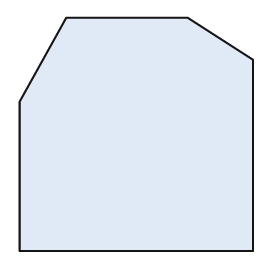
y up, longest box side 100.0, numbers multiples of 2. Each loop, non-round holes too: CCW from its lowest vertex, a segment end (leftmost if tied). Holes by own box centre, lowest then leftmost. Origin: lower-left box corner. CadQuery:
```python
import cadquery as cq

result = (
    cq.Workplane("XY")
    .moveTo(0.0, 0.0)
    .lineTo(100.0, 0.0)
    .lineTo(100.0, 82.0)
    .lineTo(72.0, 100.0)
    .lineTo(20.0, 100.0)
    .lineTo(0.0, 64.0)
    .close()
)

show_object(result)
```